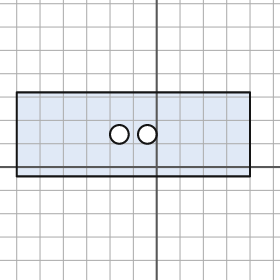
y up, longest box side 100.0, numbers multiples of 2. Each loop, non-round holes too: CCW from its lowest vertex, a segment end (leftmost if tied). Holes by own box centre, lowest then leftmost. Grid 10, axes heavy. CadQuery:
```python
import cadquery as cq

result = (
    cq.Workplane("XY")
    .moveTo(-60.0, -4.0)
    .lineTo(40.0, -4.0)
    .lineTo(40.0, 32.0)
    .lineTo(-60.0, 32.0)
    .close()
    .moveTo(-16.0, 14.0)
    .circle(4.0)
    .moveTo(-4.0, 14.0)
    .circle(4.0)
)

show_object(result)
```